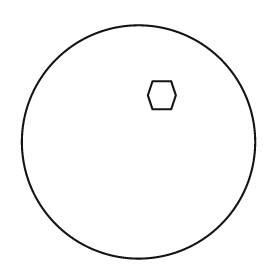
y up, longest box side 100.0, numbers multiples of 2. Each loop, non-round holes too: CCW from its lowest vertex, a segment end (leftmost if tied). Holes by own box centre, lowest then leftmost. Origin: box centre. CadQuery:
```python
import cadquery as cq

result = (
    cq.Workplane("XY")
    .moveTo(0.0, 0.0)
    .circle(50.0)
    .moveTo(6.0, 14.0)
    .lineTo(14.0, 14.0)
    .lineTo(16.0, 20.0)
    .lineTo(14.0, 26.0)
    .lineTo(6.0, 26.0)
    .lineTo(4.0, 20.0)
    .close()
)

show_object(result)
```